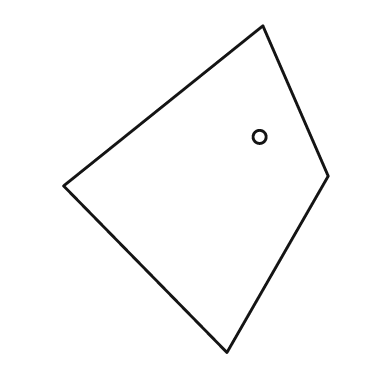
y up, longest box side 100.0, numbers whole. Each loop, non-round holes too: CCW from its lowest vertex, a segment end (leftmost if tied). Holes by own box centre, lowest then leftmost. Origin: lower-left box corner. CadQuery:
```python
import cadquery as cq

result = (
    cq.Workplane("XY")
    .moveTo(50.0, 0.0)
    .lineTo(81.0, 54.0)
    .lineTo(61.0, 100.0)
    .lineTo(0.0, 51.0)
    .close()
    .moveTo(60.0, 66.0)
    .circle(2.0)
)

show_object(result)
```